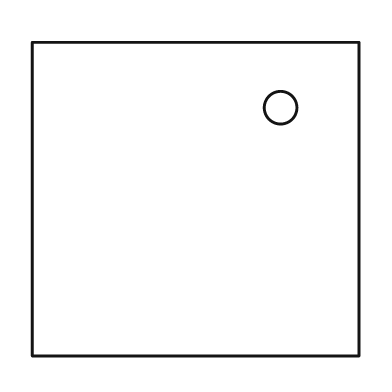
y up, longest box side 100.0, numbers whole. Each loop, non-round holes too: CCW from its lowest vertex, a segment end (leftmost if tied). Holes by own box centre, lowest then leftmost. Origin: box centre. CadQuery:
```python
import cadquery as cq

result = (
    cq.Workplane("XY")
    .moveTo(-50.0, -48.0)
    .lineTo(50.0, -48.0)
    .lineTo(50.0, 48.0)
    .lineTo(-50.0, 48.0)
    .close()
    .moveTo(26.0, 28.0)
    .circle(5.0)
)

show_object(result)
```